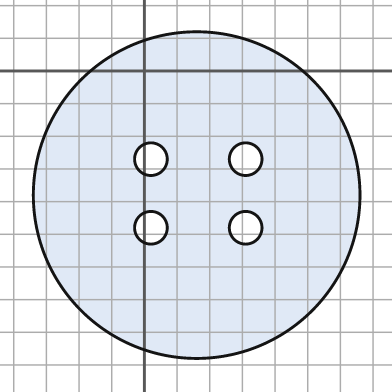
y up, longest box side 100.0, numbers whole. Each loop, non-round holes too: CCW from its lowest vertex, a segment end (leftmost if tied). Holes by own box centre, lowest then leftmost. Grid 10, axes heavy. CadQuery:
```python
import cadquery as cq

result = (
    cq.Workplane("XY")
    .moveTo(16.0, -38.0)
    .circle(50.0)
    .moveTo(2.0, -48.0)
    .circle(5.0)
    .moveTo(31.0, -48.0)
    .circle(5.0)
    .moveTo(2.0, -27.0)
    .circle(5.0)
    .moveTo(31.0, -27.0)
    .circle(5.0)
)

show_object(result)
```